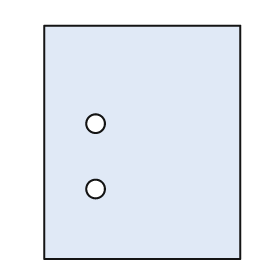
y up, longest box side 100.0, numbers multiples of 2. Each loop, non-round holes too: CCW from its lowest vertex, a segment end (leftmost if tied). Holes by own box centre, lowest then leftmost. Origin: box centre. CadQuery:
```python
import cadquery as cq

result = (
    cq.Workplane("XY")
    .moveTo(-42.0, -50.0)
    .lineTo(42.0, -50.0)
    .lineTo(42.0, 50.0)
    .lineTo(-42.0, 50.0)
    .close()
    .moveTo(-20.0, -20.0)
    .circle(4.0)
    .moveTo(-20.0, 8.0)
    .circle(4.0)
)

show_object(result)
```